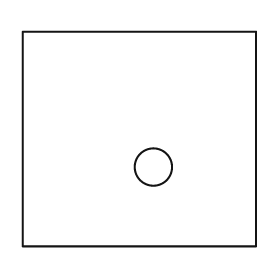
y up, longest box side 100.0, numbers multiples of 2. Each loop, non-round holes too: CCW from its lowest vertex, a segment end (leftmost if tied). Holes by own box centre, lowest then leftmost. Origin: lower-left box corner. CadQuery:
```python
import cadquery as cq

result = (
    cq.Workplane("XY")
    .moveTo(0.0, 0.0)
    .lineTo(100.0, 0.0)
    .lineTo(100.0, 92.0)
    .lineTo(0.0, 92.0)
    .close()
    .moveTo(56.0, 34.0)
    .circle(8.0)
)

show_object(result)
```